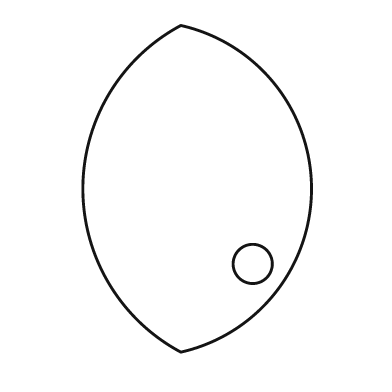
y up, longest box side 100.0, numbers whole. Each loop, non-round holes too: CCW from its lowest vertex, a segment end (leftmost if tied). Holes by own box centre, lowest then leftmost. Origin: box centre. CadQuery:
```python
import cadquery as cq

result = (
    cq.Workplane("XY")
    .moveTo(-5.0, -50.0)
    .threePointArc((35.0, 0.0), (-5.0, 50.0))
    .threePointArc((-35.0, 0.0), (-5.0, -50.0))
    .close()
    .moveTo(17.0, -23.0)
    .circle(6.0)
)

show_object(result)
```